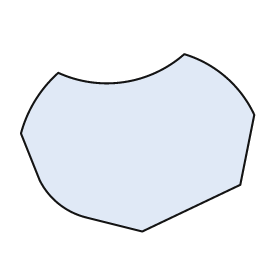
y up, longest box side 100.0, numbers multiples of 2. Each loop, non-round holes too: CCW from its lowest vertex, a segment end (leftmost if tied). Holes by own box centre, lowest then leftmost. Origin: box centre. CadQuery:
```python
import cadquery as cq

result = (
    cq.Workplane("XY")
    .moveTo(2.0, -38.0)
    .lineTo(44.0, -18.0)
    .lineTo(50.0, 12.0)
    .threePointArc((38.0, 28.0), (20.0, 38.0))
    .threePointArc((-6.0, 26.0), (-34.0, 30.0))
    .threePointArc((-44.0, 18.0), (-50.0, 4.0))
    .lineTo(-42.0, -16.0)
    .threePointArc((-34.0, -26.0), (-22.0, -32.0))
    .close()
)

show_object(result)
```